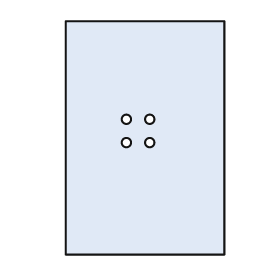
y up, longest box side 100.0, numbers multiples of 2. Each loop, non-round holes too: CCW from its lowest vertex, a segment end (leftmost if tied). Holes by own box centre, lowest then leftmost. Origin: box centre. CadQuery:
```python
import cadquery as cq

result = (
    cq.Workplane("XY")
    .moveTo(-34.0, -50.0)
    .lineTo(34.0, -50.0)
    .lineTo(34.0, 50.0)
    .lineTo(-34.0, 50.0)
    .close()
    .moveTo(-8.0, -2.0)
    .circle(2.0)
    .moveTo(2.0, -2.0)
    .circle(2.0)
    .moveTo(-8.0, 8.0)
    .circle(2.0)
    .moveTo(2.0, 8.0)
    .circle(2.0)
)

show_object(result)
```